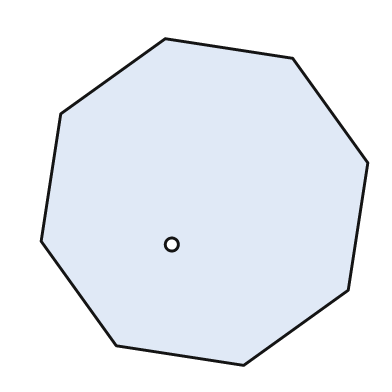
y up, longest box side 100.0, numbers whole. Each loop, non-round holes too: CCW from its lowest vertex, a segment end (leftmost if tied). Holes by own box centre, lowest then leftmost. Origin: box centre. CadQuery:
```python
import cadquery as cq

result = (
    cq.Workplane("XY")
    .moveTo(12.0, -50.0)
    .lineTo(44.0, -27.0)
    .lineTo(50.0, 12.0)
    .lineTo(27.0, 44.0)
    .lineTo(-12.0, 50.0)
    .lineTo(-44.0, 27.0)
    .lineTo(-50.0, -12.0)
    .lineTo(-27.0, -44.0)
    .close()
    .moveTo(-10.0, -13.0)
    .circle(2.0)
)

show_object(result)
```